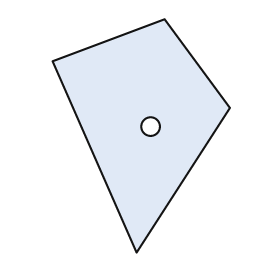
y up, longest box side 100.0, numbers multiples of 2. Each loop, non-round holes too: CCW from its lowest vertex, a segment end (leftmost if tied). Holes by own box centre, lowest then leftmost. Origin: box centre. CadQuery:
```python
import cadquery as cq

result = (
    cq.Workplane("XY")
    .moveTo(-2.0, -50.0)
    .lineTo(38.0, 12.0)
    .lineTo(10.0, 50.0)
    .lineTo(-38.0, 32.0)
    .close()
    .moveTo(4.0, 4.0)
    .circle(4.0)
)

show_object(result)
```